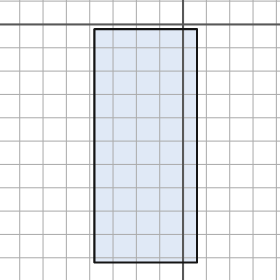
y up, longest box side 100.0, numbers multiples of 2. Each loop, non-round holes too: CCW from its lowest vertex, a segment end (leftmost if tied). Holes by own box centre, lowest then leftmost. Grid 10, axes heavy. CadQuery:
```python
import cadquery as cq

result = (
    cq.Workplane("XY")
    .moveTo(-38.0, -102.0)
    .lineTo(6.0, -102.0)
    .lineTo(6.0, -2.0)
    .lineTo(-38.0, -2.0)
    .close()
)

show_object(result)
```